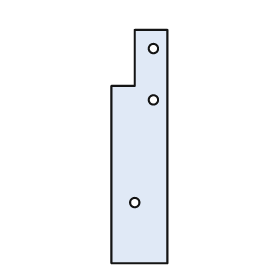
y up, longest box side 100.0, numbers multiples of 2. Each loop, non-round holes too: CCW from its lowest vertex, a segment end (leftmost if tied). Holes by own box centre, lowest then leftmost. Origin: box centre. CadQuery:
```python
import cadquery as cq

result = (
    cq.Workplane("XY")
    .moveTo(-12.0, -50.0)
    .lineTo(12.0, -50.0)
    .lineTo(12.0, 50.0)
    .lineTo(-2.0, 50.0)
    .lineTo(-2.0, 26.0)
    .lineTo(-12.0, 26.0)
    .close()
    .moveTo(-2.0, -24.0)
    .circle(2.0)
    .moveTo(6.0, 20.0)
    .circle(2.0)
    .moveTo(6.0, 42.0)
    .circle(2.0)
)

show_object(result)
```